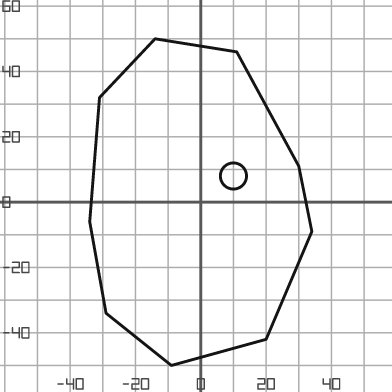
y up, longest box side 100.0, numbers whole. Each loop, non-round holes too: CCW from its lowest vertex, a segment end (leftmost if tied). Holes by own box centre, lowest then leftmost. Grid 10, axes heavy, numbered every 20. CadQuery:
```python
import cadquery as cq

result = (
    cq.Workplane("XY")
    .moveTo(-9.0, -50.0)
    .lineTo(20.0, -42.0)
    .lineTo(34.0, -9.0)
    .lineTo(30.0, 11.0)
    .lineTo(11.0, 46.0)
    .lineTo(-14.0, 50.0)
    .lineTo(-31.0, 32.0)
    .lineTo(-34.0, -6.0)
    .lineTo(-29.0, -34.0)
    .close()
    .moveTo(10.0, 8.0)
    .circle(4.0)
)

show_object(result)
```